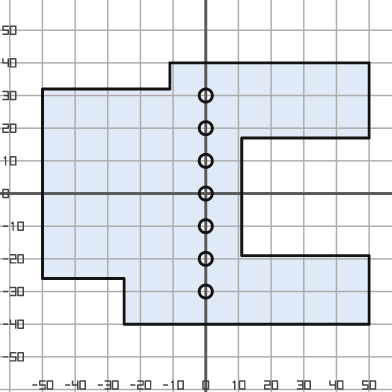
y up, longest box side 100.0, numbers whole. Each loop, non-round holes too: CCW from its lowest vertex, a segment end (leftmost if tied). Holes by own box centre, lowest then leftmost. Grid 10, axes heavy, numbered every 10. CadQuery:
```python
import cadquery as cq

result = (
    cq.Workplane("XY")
    .moveTo(-25.0, -40.0)
    .lineTo(50.0, -40.0)
    .lineTo(50.0, -19.0)
    .lineTo(11.0, -19.0)
    .lineTo(11.0, 17.0)
    .lineTo(50.0, 17.0)
    .lineTo(50.0, 40.0)
    .lineTo(-11.0, 40.0)
    .lineTo(-11.0, 32.0)
    .lineTo(-50.0, 32.0)
    .lineTo(-50.0, -26.0)
    .lineTo(-25.0, -26.0)
    .close()
    .moveTo(0.0, -30.0)
    .circle(2.0)
    .moveTo(0.0, -20.0)
    .circle(2.0)
    .moveTo(0.0, -10.0)
    .circle(2.0)
    .moveTo(0.0, 0.0)
    .circle(2.0)
    .moveTo(0.0, 10.0)
    .circle(2.0)
    .moveTo(0.0, 20.0)
    .circle(2.0)
    .moveTo(0.0, 30.0)
    .circle(2.0)
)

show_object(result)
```